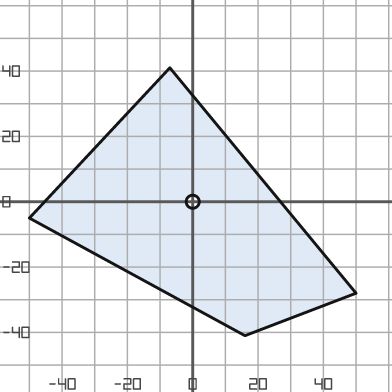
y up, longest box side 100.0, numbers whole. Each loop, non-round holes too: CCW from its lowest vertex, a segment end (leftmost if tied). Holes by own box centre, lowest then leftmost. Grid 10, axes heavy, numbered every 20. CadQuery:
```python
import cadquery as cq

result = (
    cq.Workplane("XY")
    .moveTo(16.0, -41.0)
    .lineTo(50.0, -28.0)
    .lineTo(-7.0, 41.0)
    .lineTo(-50.0, -5.0)
    .close()
    .moveTo(0.0, 0.0)
    .circle(2.0)
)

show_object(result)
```